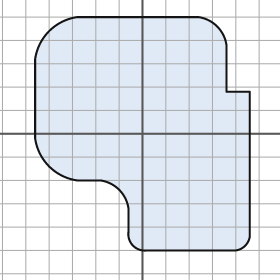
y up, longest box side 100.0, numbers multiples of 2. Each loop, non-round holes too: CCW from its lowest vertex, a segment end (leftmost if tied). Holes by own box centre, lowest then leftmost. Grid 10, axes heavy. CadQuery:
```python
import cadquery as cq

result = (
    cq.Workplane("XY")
    .moveTo(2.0, -50.0)
    .lineTo(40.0, -50.0)
    .threePointArc((44.0, -48.0), (46.0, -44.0))
    .lineTo(46.0, 18.0)
    .lineTo(36.0, 18.0)
    .lineTo(36.0, 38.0)
    .threePointArc((32.0, 46.0), (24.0, 50.0))
    .lineTo(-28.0, 50.0)
    .threePointArc((-40.0, 44.0), (-46.0, 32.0))
    .lineTo(-46.0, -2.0)
    .threePointArc((-40.0, -14.0), (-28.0, -20.0))
    .lineTo(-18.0, -20.0)
    .threePointArc((-10.0, -24.0), (-6.0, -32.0))
    .lineTo(-6.0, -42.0)
    .threePointArc((-4.0, -48.0), (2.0, -50.0))
    .close()
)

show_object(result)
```